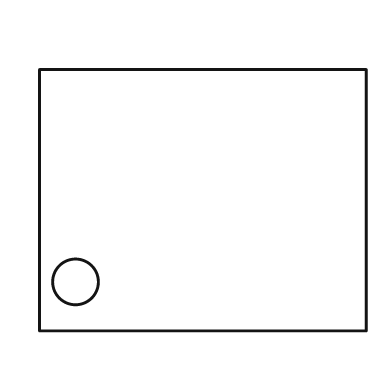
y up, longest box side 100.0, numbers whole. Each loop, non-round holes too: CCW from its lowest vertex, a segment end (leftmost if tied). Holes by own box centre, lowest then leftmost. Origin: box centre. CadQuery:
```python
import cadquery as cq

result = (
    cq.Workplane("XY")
    .moveTo(-50.0, -40.0)
    .lineTo(50.0, -40.0)
    .lineTo(50.0, 40.0)
    .lineTo(-50.0, 40.0)
    .close()
    .moveTo(-39.0, -25.0)
    .circle(7.0)
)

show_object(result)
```